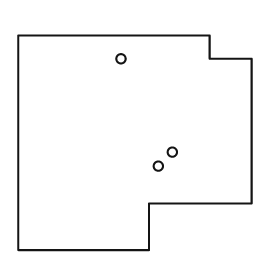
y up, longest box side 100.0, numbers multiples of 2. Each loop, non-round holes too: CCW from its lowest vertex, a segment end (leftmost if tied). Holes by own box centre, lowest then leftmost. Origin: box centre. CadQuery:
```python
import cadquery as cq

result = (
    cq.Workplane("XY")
    .moveTo(-50.0, -46.0)
    .lineTo(6.0, -46.0)
    .lineTo(6.0, -26.0)
    .lineTo(50.0, -26.0)
    .lineTo(50.0, 36.0)
    .lineTo(32.0, 36.0)
    .lineTo(32.0, 46.0)
    .lineTo(-50.0, 46.0)
    .close()
    .moveTo(10.0, -10.0)
    .circle(2.0)
    .moveTo(16.0, -4.0)
    .circle(2.0)
    .moveTo(-6.0, 36.0)
    .circle(2.0)
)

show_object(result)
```